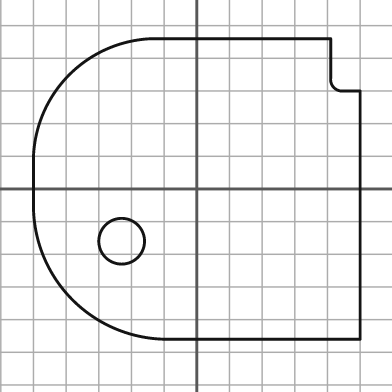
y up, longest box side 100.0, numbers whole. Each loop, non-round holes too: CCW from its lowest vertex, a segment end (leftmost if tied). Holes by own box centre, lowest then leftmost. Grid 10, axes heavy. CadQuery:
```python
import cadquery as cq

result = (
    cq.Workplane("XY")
    .moveTo(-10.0, -46.0)
    .lineTo(50.0, -46.0)
    .lineTo(50.0, 30.0)
    .lineTo(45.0, 30.0)
    .threePointArc((42.0, 31.0), (41.0, 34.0))
    .lineTo(41.0, 46.0)
    .lineTo(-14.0, 46.0)
    .threePointArc((-39.0, 35.0), (-50.0, 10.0))
    .lineTo(-50.0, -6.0)
    .threePointArc((-38.0, -34.0), (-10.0, -46.0))
    .close()
    .moveTo(-23.0, -16.0)
    .circle(7.0)
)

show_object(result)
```